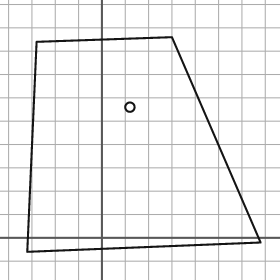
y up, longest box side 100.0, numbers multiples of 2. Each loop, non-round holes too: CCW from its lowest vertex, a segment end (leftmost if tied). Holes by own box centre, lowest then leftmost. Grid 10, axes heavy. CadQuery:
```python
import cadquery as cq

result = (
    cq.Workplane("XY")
    .moveTo(-32.0, -6.0)
    .lineTo(68.0, -2.0)
    .lineTo(30.0, 86.0)
    .lineTo(-28.0, 84.0)
    .close()
    .moveTo(12.0, 56.0)
    .circle(2.0)
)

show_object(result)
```